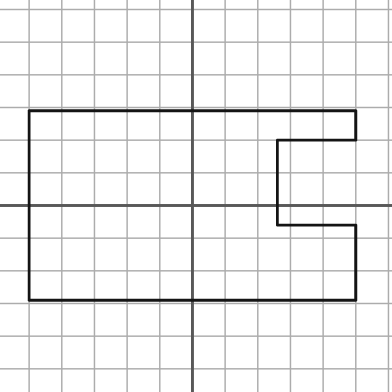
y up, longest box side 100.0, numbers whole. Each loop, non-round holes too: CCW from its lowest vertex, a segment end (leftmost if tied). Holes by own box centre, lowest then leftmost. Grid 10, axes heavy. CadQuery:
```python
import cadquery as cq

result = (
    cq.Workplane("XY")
    .moveTo(-50.0, -29.0)
    .lineTo(50.0, -29.0)
    .lineTo(50.0, -6.0)
    .lineTo(26.0, -6.0)
    .lineTo(26.0, 20.0)
    .lineTo(50.0, 20.0)
    .lineTo(50.0, 29.0)
    .lineTo(-50.0, 29.0)
    .close()
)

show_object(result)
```